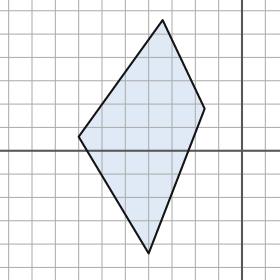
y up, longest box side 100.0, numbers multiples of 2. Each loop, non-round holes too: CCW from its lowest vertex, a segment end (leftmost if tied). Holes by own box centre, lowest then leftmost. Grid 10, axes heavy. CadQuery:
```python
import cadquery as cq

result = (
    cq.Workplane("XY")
    .moveTo(-40.0, -44.0)
    .lineTo(-16.0, 18.0)
    .lineTo(-34.0, 56.0)
    .lineTo(-70.0, 6.0)
    .close()
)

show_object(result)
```